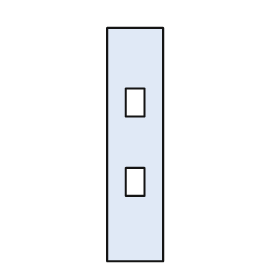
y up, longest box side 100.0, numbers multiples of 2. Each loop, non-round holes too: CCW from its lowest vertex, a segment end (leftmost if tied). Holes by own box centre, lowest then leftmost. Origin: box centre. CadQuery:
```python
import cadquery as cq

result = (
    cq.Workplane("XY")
    .moveTo(-12.0, -50.0)
    .lineTo(12.0, -50.0)
    .lineTo(12.0, 50.0)
    .lineTo(-12.0, 50.0)
    .close()
    .moveTo(-4.0, -22.0)
    .lineTo(4.0, -22.0)
    .lineTo(4.0, -10.0)
    .lineTo(-4.0, -10.0)
    .close()
    .moveTo(-4.0, 12.0)
    .lineTo(4.0, 12.0)
    .lineTo(4.0, 24.0)
    .lineTo(-4.0, 24.0)
    .close()
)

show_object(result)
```